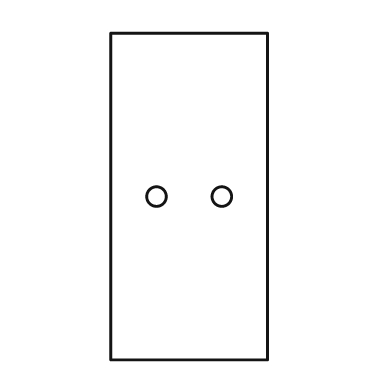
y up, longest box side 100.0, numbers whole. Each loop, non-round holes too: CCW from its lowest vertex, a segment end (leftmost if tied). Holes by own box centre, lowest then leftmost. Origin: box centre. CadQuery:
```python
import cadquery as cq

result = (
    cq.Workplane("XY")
    .moveTo(-24.0, -50.0)
    .lineTo(24.0, -50.0)
    .lineTo(24.0, 50.0)
    .lineTo(-24.0, 50.0)
    .close()
    .moveTo(-10.0, 0.0)
    .circle(3.0)
    .moveTo(10.0, 0.0)
    .circle(3.0)
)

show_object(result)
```